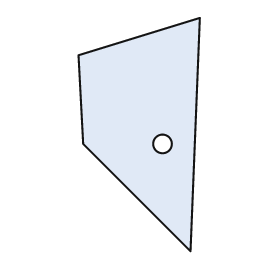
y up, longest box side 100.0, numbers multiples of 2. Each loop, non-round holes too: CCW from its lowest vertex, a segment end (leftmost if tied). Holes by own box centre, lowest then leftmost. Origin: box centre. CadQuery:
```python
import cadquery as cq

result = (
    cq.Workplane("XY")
    .moveTo(22.0, -50.0)
    .lineTo(26.0, 50.0)
    .lineTo(-26.0, 34.0)
    .lineTo(-24.0, -4.0)
    .close()
    .moveTo(10.0, -4.0)
    .circle(4.0)
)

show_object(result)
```